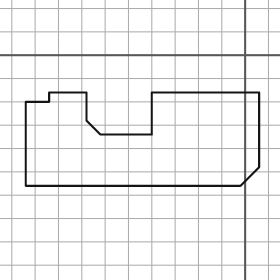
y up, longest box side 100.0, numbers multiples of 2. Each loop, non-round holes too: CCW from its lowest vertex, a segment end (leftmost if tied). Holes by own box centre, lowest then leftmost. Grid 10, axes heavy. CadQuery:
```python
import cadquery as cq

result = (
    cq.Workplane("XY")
    .moveTo(-94.0, -56.0)
    .lineTo(-2.0, -56.0)
    .lineTo(6.0, -48.0)
    .lineTo(6.0, -16.0)
    .lineTo(-40.0, -16.0)
    .lineTo(-40.0, -34.0)
    .lineTo(-62.0, -34.0)
    .lineTo(-68.0, -28.0)
    .lineTo(-68.0, -16.0)
    .lineTo(-84.0, -16.0)
    .lineTo(-84.0, -20.0)
    .lineTo(-94.0, -20.0)
    .close()
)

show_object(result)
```